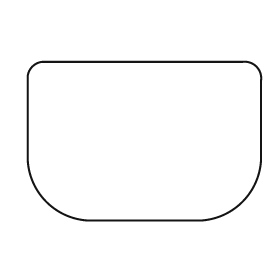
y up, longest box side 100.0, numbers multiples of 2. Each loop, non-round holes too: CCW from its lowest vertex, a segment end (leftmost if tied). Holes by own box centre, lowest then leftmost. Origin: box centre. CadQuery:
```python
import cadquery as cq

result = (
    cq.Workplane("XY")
    .moveTo(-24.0, -34.0)
    .lineTo(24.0, -34.0)
    .threePointArc((42.0, -26.0), (50.0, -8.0))
    .lineTo(50.0, 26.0)
    .threePointArc((48.0, 32.0), (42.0, 34.0))
    .lineTo(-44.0, 34.0)
    .threePointArc((-48.0, 32.0), (-50.0, 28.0))
    .lineTo(-50.0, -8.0)
    .threePointArc((-42.0, -26.0), (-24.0, -34.0))
    .close()
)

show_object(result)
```